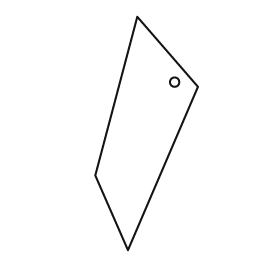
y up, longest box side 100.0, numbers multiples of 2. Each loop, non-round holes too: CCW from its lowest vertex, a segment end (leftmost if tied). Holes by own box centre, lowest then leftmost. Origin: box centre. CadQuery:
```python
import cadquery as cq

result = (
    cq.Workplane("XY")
    .moveTo(-8.0, -50.0)
    .lineTo(22.0, 20.0)
    .lineTo(-4.0, 50.0)
    .lineTo(-22.0, -18.0)
    .close()
    .moveTo(12.0, 22.0)
    .circle(2.0)
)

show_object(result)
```